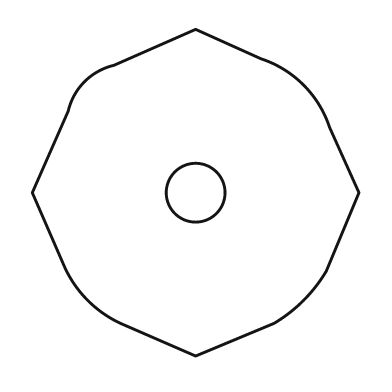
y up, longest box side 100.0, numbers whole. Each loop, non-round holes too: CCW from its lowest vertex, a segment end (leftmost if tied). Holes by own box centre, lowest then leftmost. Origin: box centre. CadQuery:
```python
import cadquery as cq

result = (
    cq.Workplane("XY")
    .moveTo(0.0, -50.0)
    .lineTo(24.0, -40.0)
    .threePointArc((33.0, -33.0), (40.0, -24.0))
    .lineTo(50.0, 0.0)
    .lineTo(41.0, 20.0)
    .threePointArc((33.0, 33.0), (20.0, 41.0))
    .lineTo(0.0, 50.0)
    .lineTo(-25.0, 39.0)
    .threePointArc((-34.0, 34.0), (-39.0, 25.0))
    .lineTo(-50.0, 0.0)
    .lineTo(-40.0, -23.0)
    .threePointArc((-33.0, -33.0), (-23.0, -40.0))
    .close()
    .moveTo(0.0, 0.0)
    .circle(9.0)
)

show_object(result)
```